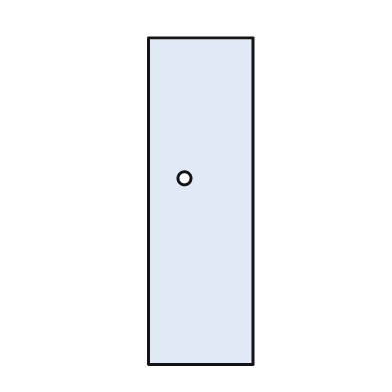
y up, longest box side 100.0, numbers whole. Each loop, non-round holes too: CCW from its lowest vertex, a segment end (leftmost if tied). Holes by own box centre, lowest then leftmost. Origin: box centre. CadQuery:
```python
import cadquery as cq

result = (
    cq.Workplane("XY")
    .moveTo(-16.0, -50.0)
    .lineTo(16.0, -50.0)
    .lineTo(16.0, 50.0)
    .lineTo(-16.0, 50.0)
    .close()
    .moveTo(-5.0, 7.0)
    .circle(2.0)
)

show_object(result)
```